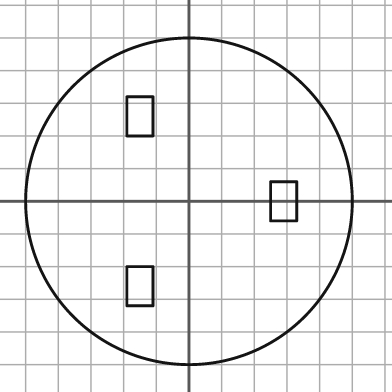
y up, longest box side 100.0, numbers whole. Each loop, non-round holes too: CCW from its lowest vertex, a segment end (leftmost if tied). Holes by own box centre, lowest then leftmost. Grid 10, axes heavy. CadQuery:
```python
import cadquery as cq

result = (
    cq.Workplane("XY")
    .moveTo(0.0, 0.0)
    .circle(50.0)
    .moveTo(-19.0, -32.0)
    .lineTo(-11.0, -32.0)
    .lineTo(-11.0, -20.0)
    .lineTo(-19.0, -20.0)
    .close()
    .moveTo(25.0, -6.0)
    .lineTo(33.0, -6.0)
    .lineTo(33.0, 6.0)
    .lineTo(25.0, 6.0)
    .close()
    .moveTo(-19.0, 20.0)
    .lineTo(-11.0, 20.0)
    .lineTo(-11.0, 32.0)
    .lineTo(-19.0, 32.0)
    .close()
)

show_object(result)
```